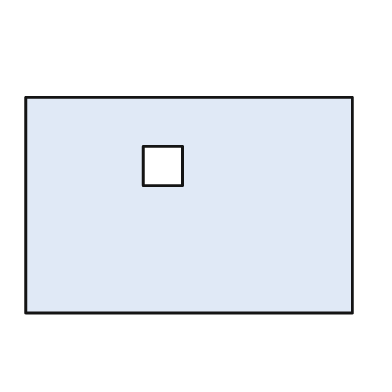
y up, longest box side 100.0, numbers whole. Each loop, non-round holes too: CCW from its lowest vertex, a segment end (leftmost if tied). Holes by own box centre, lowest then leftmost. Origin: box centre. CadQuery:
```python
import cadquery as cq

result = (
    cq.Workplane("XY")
    .moveTo(-50.0, -33.0)
    .lineTo(50.0, -33.0)
    .lineTo(50.0, 33.0)
    .lineTo(-50.0, 33.0)
    .close()
    .moveTo(-14.0, 6.0)
    .lineTo(-2.0, 6.0)
    .lineTo(-2.0, 18.0)
    .lineTo(-14.0, 18.0)
    .close()
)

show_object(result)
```